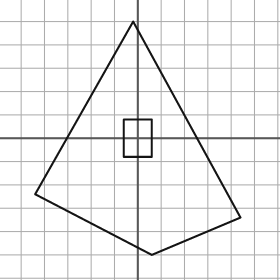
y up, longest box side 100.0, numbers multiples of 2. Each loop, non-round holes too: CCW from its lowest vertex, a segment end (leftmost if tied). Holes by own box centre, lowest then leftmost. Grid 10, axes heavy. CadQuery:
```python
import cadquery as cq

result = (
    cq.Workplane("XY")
    .moveTo(6.0, -50.0)
    .lineTo(44.0, -34.0)
    .lineTo(-2.0, 50.0)
    .lineTo(-44.0, -24.0)
    .close()
    .moveTo(-6.0, -8.0)
    .lineTo(6.0, -8.0)
    .lineTo(6.0, 8.0)
    .lineTo(-6.0, 8.0)
    .close()
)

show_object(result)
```